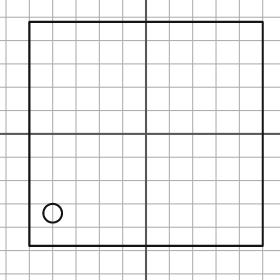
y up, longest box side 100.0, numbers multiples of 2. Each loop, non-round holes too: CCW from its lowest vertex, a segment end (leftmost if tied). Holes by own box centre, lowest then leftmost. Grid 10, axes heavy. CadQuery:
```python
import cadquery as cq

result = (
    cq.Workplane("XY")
    .moveTo(-50.0, -48.0)
    .lineTo(50.0, -48.0)
    .lineTo(50.0, 48.0)
    .lineTo(-50.0, 48.0)
    .close()
    .moveTo(-40.0, -34.0)
    .circle(4.0)
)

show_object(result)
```